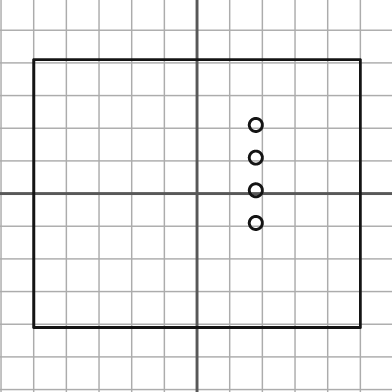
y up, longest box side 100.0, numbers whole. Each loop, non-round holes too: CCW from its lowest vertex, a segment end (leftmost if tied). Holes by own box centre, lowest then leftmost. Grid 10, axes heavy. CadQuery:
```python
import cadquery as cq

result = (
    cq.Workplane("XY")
    .moveTo(-50.0, -41.0)
    .lineTo(50.0, -41.0)
    .lineTo(50.0, 41.0)
    .lineTo(-50.0, 41.0)
    .close()
    .moveTo(18.0, -9.0)
    .circle(2.0)
    .moveTo(18.0, 1.0)
    .circle(2.0)
    .moveTo(18.0, 11.0)
    .circle(2.0)
    .moveTo(18.0, 21.0)
    .circle(2.0)
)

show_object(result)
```